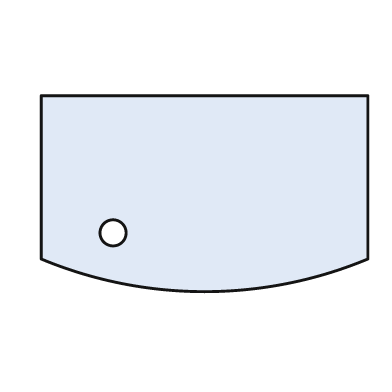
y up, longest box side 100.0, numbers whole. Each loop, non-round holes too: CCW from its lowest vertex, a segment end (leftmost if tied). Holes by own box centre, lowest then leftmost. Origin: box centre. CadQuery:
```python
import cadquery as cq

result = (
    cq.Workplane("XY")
    .moveTo(-50.0, -20.0)
    .threePointArc((0.0, -30.0), (50.0, -20.0))
    .lineTo(50.0, 30.0)
    .lineTo(-50.0, 30.0)
    .close()
    .moveTo(-28.0, -12.0)
    .circle(4.0)
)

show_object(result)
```